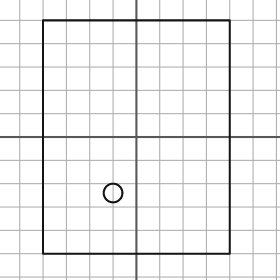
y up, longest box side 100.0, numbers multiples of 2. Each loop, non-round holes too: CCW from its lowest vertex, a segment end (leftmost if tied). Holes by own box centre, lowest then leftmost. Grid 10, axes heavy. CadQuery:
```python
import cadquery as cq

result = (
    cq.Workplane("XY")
    .moveTo(-40.0, -50.0)
    .lineTo(40.0, -50.0)
    .lineTo(40.0, 50.0)
    .lineTo(-40.0, 50.0)
    .close()
    .moveTo(-10.0, -24.0)
    .circle(4.0)
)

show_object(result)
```